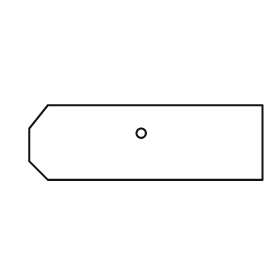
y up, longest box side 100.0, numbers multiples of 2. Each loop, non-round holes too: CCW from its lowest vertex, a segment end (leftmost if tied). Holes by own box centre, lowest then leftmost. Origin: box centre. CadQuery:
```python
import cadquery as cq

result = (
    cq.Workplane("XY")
    .moveTo(-42.0, -16.0)
    .lineTo(50.0, -16.0)
    .lineTo(50.0, 16.0)
    .lineTo(-42.0, 16.0)
    .lineTo(-50.0, 6.0)
    .lineTo(-50.0, -8.0)
    .close()
    .moveTo(-2.0, 4.0)
    .circle(2.0)
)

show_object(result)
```